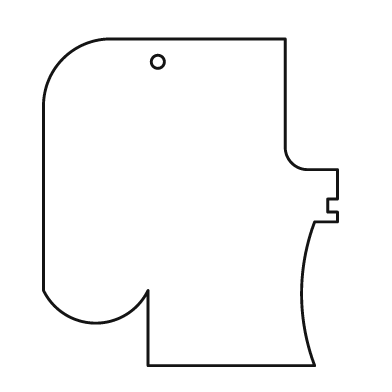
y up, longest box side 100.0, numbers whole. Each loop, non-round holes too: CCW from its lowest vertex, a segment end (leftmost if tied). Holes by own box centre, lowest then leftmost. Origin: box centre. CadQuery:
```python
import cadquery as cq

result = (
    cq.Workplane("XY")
    .moveTo(-13.0, -50.0)
    .lineTo(38.0, -50.0)
    .threePointArc((34.0, -28.0), (38.0, -6.0))
    .lineTo(45.0, -6.0)
    .lineTo(45.0, -3.0)
    .lineTo(42.0, -3.0)
    .lineTo(42.0, 1.0)
    .lineTo(45.0, 1.0)
    .lineTo(45.0, 10.0)
    .lineTo(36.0, 10.0)
    .threePointArc((31.0, 12.0), (29.0, 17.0))
    .lineTo(29.0, 50.0)
    .lineTo(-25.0, 50.0)
    .threePointArc((-39.0, 44.0), (-45.0, 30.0))
    .lineTo(-45.0, -27.0)
    .threePointArc((-29.0, -37.0), (-13.0, -27.0))
    .close()
    .moveTo(-10.0, 43.0)
    .circle(2.0)
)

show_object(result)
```